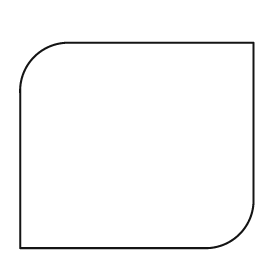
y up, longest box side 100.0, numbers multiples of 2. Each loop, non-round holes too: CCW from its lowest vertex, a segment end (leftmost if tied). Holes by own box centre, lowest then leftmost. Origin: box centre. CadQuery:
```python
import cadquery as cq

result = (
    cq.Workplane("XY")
    .moveTo(-50.0, -44.0)
    .lineTo(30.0, -44.0)
    .threePointArc((44.0, -38.0), (50.0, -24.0))
    .lineTo(50.0, 44.0)
    .lineTo(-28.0, 44.0)
    .threePointArc((-44.0, 38.0), (-50.0, 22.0))
    .close()
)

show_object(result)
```